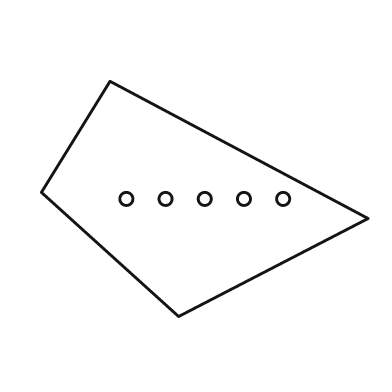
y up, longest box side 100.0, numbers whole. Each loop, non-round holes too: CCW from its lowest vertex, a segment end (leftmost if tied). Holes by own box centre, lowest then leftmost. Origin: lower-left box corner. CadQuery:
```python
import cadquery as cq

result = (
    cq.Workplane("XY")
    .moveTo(42.0, 0.0)
    .lineTo(100.0, 30.0)
    .lineTo(21.0, 72.0)
    .lineTo(0.0, 38.0)
    .close()
    .moveTo(26.0, 36.0)
    .circle(2.0)
    .moveTo(38.0, 36.0)
    .circle(2.0)
    .moveTo(50.0, 36.0)
    .circle(2.0)
    .moveTo(62.0, 36.0)
    .circle(2.0)
    .moveTo(74.0, 36.0)
    .circle(2.0)
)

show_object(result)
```